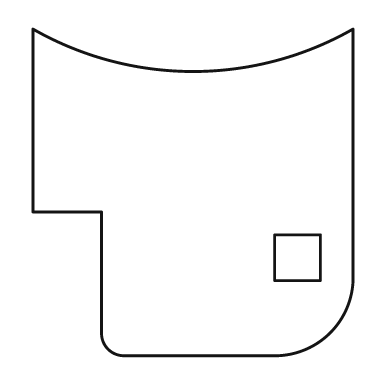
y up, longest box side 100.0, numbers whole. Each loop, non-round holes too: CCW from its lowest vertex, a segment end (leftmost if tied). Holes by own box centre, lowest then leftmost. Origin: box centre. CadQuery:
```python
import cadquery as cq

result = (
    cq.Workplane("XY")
    .moveTo(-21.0, -50.0)
    .lineTo(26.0, -50.0)
    .threePointArc((42.0, -43.0), (49.0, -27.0))
    .lineTo(49.0, 50.0)
    .threePointArc((0.0, 37.0), (-49.0, 50.0))
    .lineTo(-49.0, -6.0)
    .lineTo(-28.0, -6.0)
    .lineTo(-28.0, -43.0)
    .threePointArc((-26.0, -48.0), (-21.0, -50.0))
    .close()
    .moveTo(25.0, -27.0)
    .lineTo(39.0, -27.0)
    .lineTo(39.0, -13.0)
    .lineTo(25.0, -13.0)
    .close()
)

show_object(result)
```